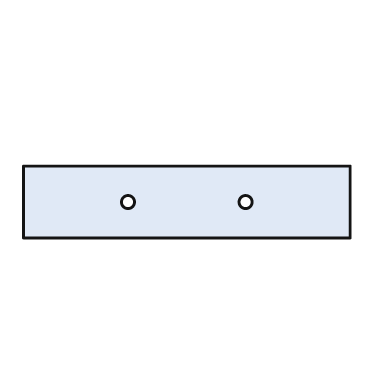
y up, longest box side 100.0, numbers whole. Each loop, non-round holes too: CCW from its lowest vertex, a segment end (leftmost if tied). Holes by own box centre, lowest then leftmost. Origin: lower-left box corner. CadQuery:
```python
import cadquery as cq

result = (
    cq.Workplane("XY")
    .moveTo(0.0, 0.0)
    .lineTo(100.0, 0.0)
    .lineTo(100.0, 22.0)
    .lineTo(0.0, 22.0)
    .close()
    .moveTo(32.0, 11.0)
    .circle(2.0)
    .moveTo(68.0, 11.0)
    .circle(2.0)
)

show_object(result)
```